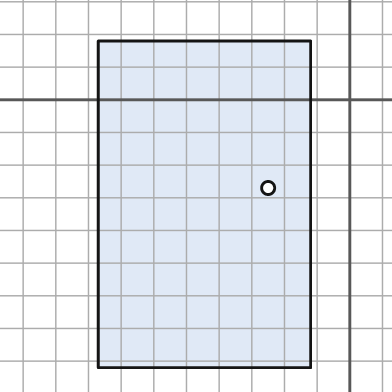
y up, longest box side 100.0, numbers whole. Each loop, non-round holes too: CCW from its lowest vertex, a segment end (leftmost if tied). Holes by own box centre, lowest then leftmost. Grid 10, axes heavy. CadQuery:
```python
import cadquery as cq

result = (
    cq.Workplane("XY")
    .moveTo(-77.0, -82.0)
    .lineTo(-12.0, -82.0)
    .lineTo(-12.0, 18.0)
    .lineTo(-77.0, 18.0)
    .close()
    .moveTo(-25.0, -27.0)
    .circle(2.0)
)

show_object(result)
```